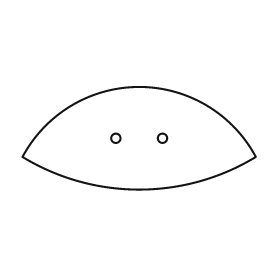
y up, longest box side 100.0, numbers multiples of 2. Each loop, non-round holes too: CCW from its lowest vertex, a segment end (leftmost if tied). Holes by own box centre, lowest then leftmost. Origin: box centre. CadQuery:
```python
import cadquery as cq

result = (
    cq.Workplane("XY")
    .moveTo(-50.0, -8.0)
    .threePointArc((0.0, -22.0), (50.0, -8.0))
    .threePointArc((0.0, 22.0), (-50.0, -8.0))
    .close()
    .moveTo(-10.0, 0.0)
    .circle(2.0)
    .moveTo(10.0, 0.0)
    .circle(2.0)
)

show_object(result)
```